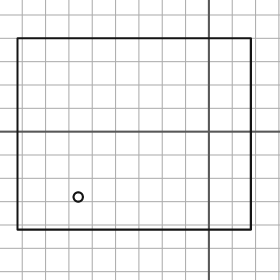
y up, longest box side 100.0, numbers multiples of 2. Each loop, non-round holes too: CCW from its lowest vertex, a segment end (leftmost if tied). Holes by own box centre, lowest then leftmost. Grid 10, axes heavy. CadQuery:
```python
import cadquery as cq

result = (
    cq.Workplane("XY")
    .moveTo(-82.0, -42.0)
    .lineTo(18.0, -42.0)
    .lineTo(18.0, 40.0)
    .lineTo(-82.0, 40.0)
    .close()
    .moveTo(-56.0, -28.0)
    .circle(2.0)
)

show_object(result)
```